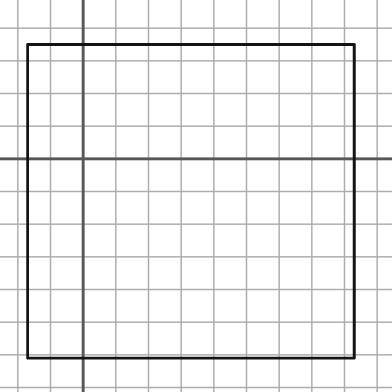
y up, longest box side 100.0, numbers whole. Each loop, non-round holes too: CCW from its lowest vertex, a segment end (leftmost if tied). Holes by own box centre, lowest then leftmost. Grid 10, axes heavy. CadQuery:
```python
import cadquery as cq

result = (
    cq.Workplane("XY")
    .moveTo(-17.0, -61.0)
    .lineTo(83.0, -61.0)
    .lineTo(83.0, 35.0)
    .lineTo(-17.0, 35.0)
    .close()
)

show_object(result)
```